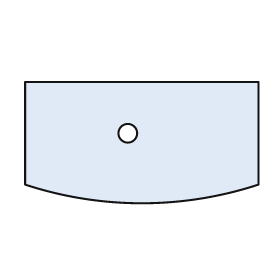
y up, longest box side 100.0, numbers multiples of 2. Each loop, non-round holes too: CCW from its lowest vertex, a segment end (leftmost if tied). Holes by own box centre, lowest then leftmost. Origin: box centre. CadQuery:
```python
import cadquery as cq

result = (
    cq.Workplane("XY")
    .moveTo(-50.0, -18.0)
    .threePointArc((0.0, -26.0), (50.0, -18.0))
    .lineTo(50.0, 26.0)
    .lineTo(-50.0, 26.0)
    .close()
    .moveTo(-6.0, 4.0)
    .circle(4.0)
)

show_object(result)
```